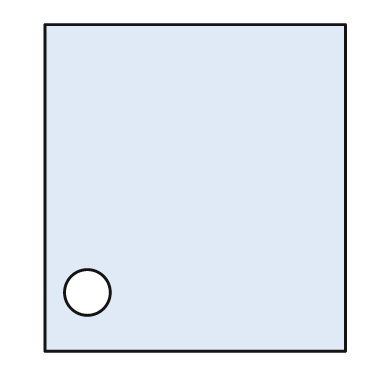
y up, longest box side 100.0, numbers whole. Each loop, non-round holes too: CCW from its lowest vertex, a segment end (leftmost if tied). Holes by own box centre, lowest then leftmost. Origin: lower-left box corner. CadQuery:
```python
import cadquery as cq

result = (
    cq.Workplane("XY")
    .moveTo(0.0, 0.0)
    .lineTo(92.0, 0.0)
    .lineTo(92.0, 100.0)
    .lineTo(0.0, 100.0)
    .close()
    .moveTo(13.0, 18.0)
    .circle(7.0)
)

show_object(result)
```